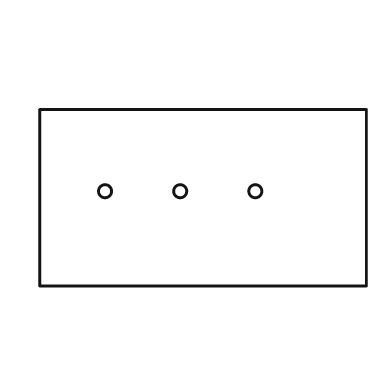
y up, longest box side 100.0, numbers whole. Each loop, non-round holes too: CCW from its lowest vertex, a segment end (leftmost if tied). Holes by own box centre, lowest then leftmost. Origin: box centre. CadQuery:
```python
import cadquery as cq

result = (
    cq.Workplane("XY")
    .moveTo(-50.0, -27.0)
    .lineTo(50.0, -27.0)
    .lineTo(50.0, 27.0)
    .lineTo(-50.0, 27.0)
    .close()
    .moveTo(-30.0, 2.0)
    .circle(2.0)
    .moveTo(-7.0, 2.0)
    .circle(2.0)
    .moveTo(16.0, 2.0)
    .circle(2.0)
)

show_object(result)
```